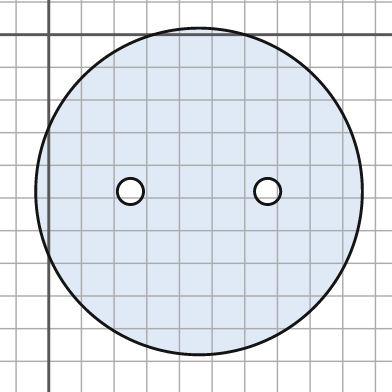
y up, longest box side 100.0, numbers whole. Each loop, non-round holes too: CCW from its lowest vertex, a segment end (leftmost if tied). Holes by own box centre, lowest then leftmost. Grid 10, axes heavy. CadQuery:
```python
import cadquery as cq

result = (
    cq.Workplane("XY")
    .moveTo(46.0, -48.0)
    .circle(50.0)
    .moveTo(25.0, -48.0)
    .circle(4.0)
    .moveTo(67.0, -48.0)
    .circle(4.0)
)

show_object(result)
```